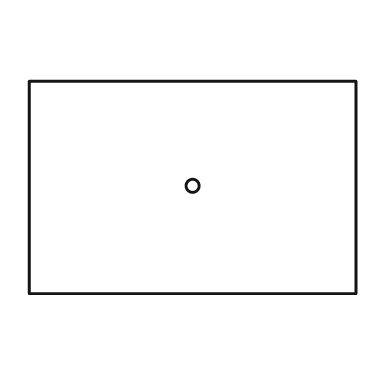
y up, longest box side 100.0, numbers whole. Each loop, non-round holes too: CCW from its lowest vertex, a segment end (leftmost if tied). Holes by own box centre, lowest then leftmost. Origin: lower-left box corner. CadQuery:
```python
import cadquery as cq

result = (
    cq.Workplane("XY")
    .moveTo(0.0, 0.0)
    .lineTo(100.0, 0.0)
    .lineTo(100.0, 65.0)
    .lineTo(0.0, 65.0)
    .close()
    .moveTo(50.0, 33.0)
    .circle(2.0)
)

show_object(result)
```